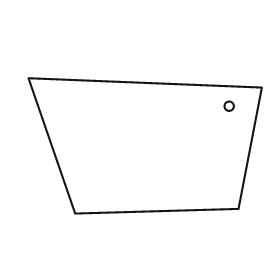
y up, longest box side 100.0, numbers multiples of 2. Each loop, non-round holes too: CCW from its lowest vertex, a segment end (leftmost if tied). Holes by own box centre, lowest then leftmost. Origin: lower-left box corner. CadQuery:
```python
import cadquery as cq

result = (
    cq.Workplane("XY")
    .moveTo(20.0, 0.0)
    .lineTo(90.0, 2.0)
    .lineTo(100.0, 54.0)
    .lineTo(0.0, 58.0)
    .close()
    .moveTo(86.0, 46.0)
    .circle(2.0)
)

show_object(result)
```